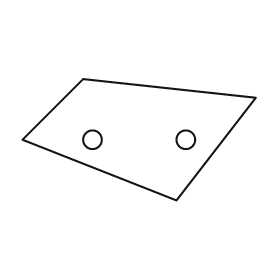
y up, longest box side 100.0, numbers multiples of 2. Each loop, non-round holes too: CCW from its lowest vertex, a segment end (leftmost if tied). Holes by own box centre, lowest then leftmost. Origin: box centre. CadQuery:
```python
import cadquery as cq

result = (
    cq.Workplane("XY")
    .moveTo(16.0, -26.0)
    .lineTo(50.0, 18.0)
    .lineTo(-24.0, 26.0)
    .lineTo(-50.0, 0.0)
    .close()
    .moveTo(-20.0, 0.0)
    .circle(4.0)
    .moveTo(20.0, 0.0)
    .circle(4.0)
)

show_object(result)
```